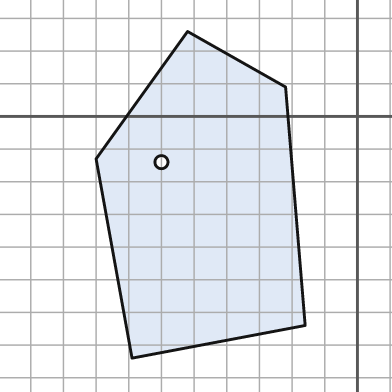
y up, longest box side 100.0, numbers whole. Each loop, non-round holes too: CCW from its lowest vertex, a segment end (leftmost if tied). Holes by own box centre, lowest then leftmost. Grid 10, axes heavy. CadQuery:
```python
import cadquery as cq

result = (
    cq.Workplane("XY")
    .moveTo(-69.0, -74.0)
    .lineTo(-16.0, -64.0)
    .lineTo(-22.0, 9.0)
    .lineTo(-52.0, 26.0)
    .lineTo(-80.0, -13.0)
    .close()
    .moveTo(-60.0, -14.0)
    .circle(2.0)
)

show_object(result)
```